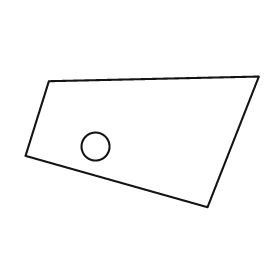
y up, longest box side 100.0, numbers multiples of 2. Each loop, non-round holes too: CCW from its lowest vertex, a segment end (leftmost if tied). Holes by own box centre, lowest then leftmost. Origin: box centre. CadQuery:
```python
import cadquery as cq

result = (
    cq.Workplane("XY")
    .moveTo(28.0, -28.0)
    .lineTo(50.0, 28.0)
    .lineTo(-40.0, 26.0)
    .lineTo(-50.0, -6.0)
    .close()
    .moveTo(-20.0, -2.0)
    .circle(6.0)
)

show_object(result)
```